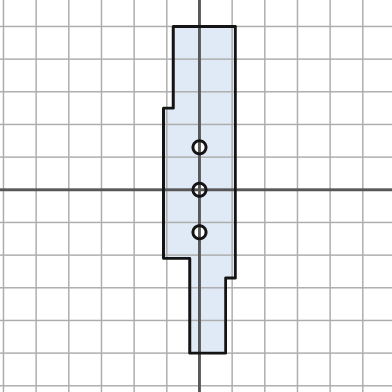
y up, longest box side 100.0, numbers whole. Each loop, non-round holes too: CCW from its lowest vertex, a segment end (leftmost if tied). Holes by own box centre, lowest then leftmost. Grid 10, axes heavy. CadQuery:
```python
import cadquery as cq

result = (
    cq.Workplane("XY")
    .moveTo(-3.0, -50.0)
    .lineTo(8.0, -50.0)
    .lineTo(8.0, -27.0)
    .lineTo(11.0, -27.0)
    .lineTo(11.0, 50.0)
    .lineTo(-8.0, 50.0)
    .lineTo(-8.0, 25.0)
    .lineTo(-11.0, 25.0)
    .lineTo(-11.0, -21.0)
    .lineTo(-3.0, -21.0)
    .close()
    .moveTo(0.0, -13.0)
    .circle(2.0)
    .moveTo(0.0, 0.0)
    .circle(2.0)
    .moveTo(0.0, 13.0)
    .circle(2.0)
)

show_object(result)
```